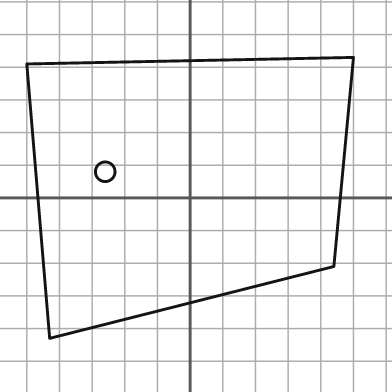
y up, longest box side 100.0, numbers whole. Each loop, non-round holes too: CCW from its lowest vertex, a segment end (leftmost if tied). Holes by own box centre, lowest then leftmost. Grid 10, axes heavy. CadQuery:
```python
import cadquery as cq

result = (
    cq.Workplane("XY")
    .moveTo(-43.0, -43.0)
    .lineTo(44.0, -21.0)
    .lineTo(50.0, 43.0)
    .lineTo(-50.0, 41.0)
    .close()
    .moveTo(-26.0, 8.0)
    .circle(3.0)
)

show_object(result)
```